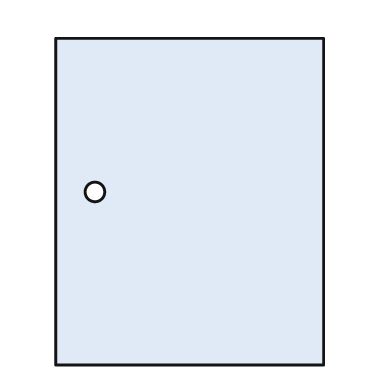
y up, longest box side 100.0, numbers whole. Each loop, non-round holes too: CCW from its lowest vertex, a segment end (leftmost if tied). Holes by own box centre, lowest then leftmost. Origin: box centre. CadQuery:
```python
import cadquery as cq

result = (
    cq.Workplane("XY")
    .moveTo(-41.0, -50.0)
    .lineTo(41.0, -50.0)
    .lineTo(41.0, 50.0)
    .lineTo(-41.0, 50.0)
    .close()
    .moveTo(-29.0, 3.0)
    .circle(3.0)
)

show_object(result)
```